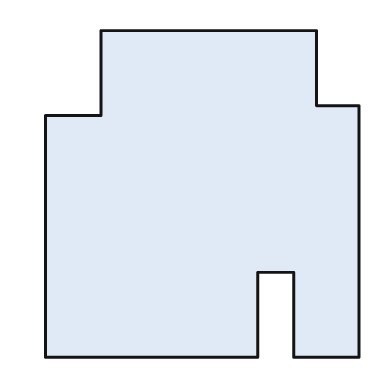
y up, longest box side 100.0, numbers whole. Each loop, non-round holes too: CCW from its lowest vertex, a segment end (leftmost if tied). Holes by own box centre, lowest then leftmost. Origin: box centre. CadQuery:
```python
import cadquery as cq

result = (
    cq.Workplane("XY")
    .moveTo(-48.0, -50.0)
    .lineTo(17.0, -50.0)
    .lineTo(17.0, -24.0)
    .lineTo(28.0, -24.0)
    .lineTo(28.0, -50.0)
    .lineTo(48.0, -50.0)
    .lineTo(48.0, 27.0)
    .lineTo(35.0, 27.0)
    .lineTo(35.0, 50.0)
    .lineTo(-31.0, 50.0)
    .lineTo(-31.0, 24.0)
    .lineTo(-48.0, 24.0)
    .close()
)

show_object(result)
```